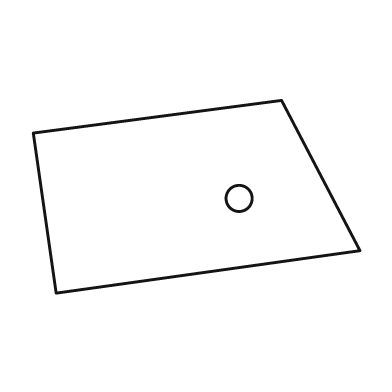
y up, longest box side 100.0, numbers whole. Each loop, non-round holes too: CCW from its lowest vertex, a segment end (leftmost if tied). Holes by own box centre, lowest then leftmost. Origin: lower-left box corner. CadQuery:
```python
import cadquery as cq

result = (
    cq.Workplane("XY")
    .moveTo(7.0, 0.0)
    .lineTo(100.0, 13.0)
    .lineTo(76.0, 59.0)
    .lineTo(0.0, 49.0)
    .close()
    .moveTo(63.0, 29.0)
    .circle(4.0)
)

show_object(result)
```